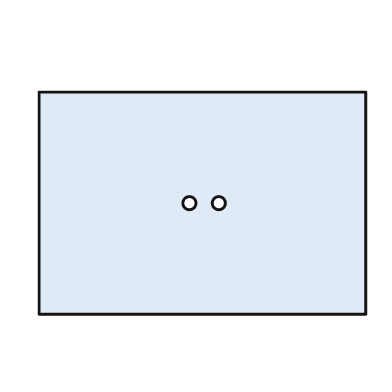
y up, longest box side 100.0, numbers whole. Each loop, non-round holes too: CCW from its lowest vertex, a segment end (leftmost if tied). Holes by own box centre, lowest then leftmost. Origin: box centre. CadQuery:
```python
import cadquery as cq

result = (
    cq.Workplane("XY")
    .moveTo(-50.0, -34.0)
    .lineTo(50.0, -34.0)
    .lineTo(50.0, 34.0)
    .lineTo(-50.0, 34.0)
    .close()
    .moveTo(-4.0, 0.0)
    .circle(2.0)
    .moveTo(5.0, 0.0)
    .circle(2.0)
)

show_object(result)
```